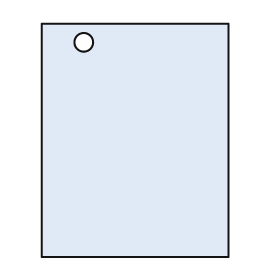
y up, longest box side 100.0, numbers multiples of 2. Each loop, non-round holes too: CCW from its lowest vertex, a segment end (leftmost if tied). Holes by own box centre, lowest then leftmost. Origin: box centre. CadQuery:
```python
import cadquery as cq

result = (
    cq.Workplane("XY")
    .moveTo(-40.0, -50.0)
    .lineTo(40.0, -50.0)
    .lineTo(40.0, 50.0)
    .lineTo(-40.0, 50.0)
    .close()
    .moveTo(-22.0, 42.0)
    .circle(4.0)
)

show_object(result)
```